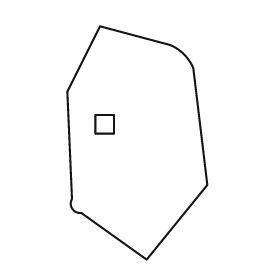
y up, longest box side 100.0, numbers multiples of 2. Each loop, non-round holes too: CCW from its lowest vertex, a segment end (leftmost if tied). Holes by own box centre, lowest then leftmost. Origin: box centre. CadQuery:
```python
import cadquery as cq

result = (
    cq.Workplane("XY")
    .moveTo(4.0, -50.0)
    .lineTo(30.0, -18.0)
    .lineTo(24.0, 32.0)
    .threePointArc((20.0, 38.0), (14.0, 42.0))
    .lineTo(-16.0, 50.0)
    .lineTo(-30.0, 22.0)
    .lineTo(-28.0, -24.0)
    .threePointArc((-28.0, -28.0), (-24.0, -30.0))
    .close()
    .moveTo(-18.0, 4.0)
    .lineTo(-10.0, 4.0)
    .lineTo(-10.0, 12.0)
    .lineTo(-18.0, 12.0)
    .close()
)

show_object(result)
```